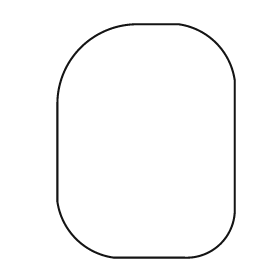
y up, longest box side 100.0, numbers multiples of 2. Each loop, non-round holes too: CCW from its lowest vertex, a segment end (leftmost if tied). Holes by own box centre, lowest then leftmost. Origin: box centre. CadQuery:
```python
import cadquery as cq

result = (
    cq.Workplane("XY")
    .moveTo(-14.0, -50.0)
    .lineTo(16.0, -50.0)
    .threePointArc((32.0, -44.0), (38.0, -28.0))
    .lineTo(38.0, 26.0)
    .threePointArc((30.0, 42.0), (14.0, 50.0))
    .lineTo(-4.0, 50.0)
    .threePointArc((-28.0, 40.0), (-38.0, 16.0))
    .lineTo(-38.0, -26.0)
    .threePointArc((-30.0, -42.0), (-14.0, -50.0))
    .close()
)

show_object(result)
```